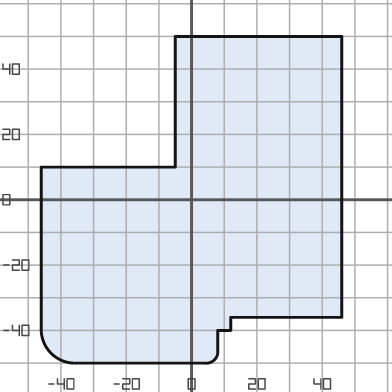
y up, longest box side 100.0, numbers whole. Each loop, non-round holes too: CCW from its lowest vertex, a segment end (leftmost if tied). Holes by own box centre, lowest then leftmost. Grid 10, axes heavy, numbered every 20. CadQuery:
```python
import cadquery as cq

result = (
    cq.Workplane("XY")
    .moveTo(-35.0, -50.0)
    .lineTo(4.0, -50.0)
    .threePointArc((7.0, -49.0), (8.0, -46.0))
    .lineTo(8.0, -40.0)
    .lineTo(12.0, -40.0)
    .lineTo(12.0, -36.0)
    .lineTo(46.0, -36.0)
    .lineTo(46.0, 50.0)
    .lineTo(-5.0, 50.0)
    .lineTo(-5.0, 10.0)
    .lineTo(-46.0, 10.0)
    .lineTo(-46.0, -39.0)
    .threePointArc((-43.0, -47.0), (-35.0, -50.0))
    .close()
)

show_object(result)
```